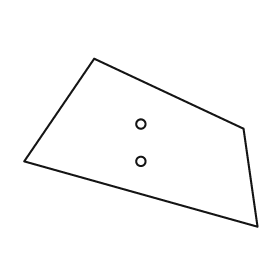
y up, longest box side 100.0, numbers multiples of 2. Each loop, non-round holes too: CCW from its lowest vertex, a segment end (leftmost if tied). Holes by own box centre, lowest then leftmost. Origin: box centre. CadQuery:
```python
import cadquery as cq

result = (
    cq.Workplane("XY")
    .moveTo(50.0, -36.0)
    .lineTo(44.0, 6.0)
    .lineTo(-20.0, 36.0)
    .lineTo(-50.0, -8.0)
    .close()
    .moveTo(0.0, -8.0)
    .circle(2.0)
    .moveTo(0.0, 8.0)
    .circle(2.0)
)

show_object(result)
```